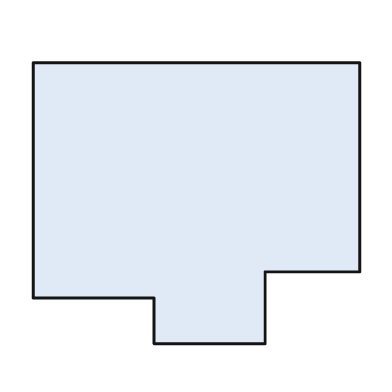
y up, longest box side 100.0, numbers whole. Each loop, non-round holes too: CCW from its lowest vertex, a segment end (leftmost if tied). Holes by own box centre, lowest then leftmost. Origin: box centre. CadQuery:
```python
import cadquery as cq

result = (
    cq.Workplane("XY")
    .moveTo(-13.0, -43.0)
    .lineTo(21.0, -43.0)
    .lineTo(21.0, -21.0)
    .lineTo(50.0, -21.0)
    .lineTo(50.0, 43.0)
    .lineTo(-50.0, 43.0)
    .lineTo(-50.0, -29.0)
    .lineTo(-13.0, -29.0)
    .close()
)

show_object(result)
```